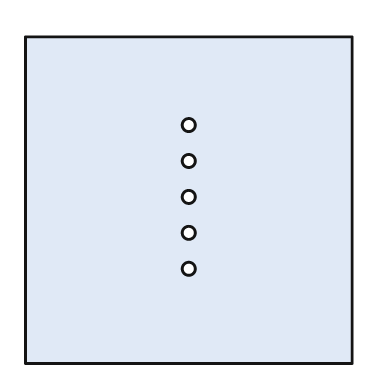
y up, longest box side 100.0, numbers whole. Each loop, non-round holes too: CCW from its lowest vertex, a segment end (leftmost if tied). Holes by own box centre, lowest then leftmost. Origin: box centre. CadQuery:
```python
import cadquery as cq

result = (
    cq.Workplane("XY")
    .moveTo(-50.0, -50.0)
    .lineTo(50.0, -50.0)
    .lineTo(50.0, 50.0)
    .lineTo(-50.0, 50.0)
    .close()
    .moveTo(0.0, -21.0)
    .circle(2.0)
    .moveTo(0.0, -10.0)
    .circle(2.0)
    .moveTo(0.0, 1.0)
    .circle(2.0)
    .moveTo(0.0, 12.0)
    .circle(2.0)
    .moveTo(0.0, 23.0)
    .circle(2.0)
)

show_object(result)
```